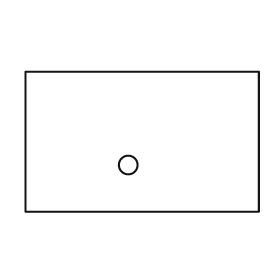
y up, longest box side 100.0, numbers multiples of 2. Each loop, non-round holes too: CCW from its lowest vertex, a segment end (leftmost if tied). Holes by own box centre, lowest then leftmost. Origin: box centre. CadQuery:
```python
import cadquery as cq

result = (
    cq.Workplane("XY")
    .moveTo(-50.0, -30.0)
    .lineTo(50.0, -30.0)
    .lineTo(50.0, 30.0)
    .lineTo(-50.0, 30.0)
    .close()
    .moveTo(-6.0, -10.0)
    .circle(4.0)
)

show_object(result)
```